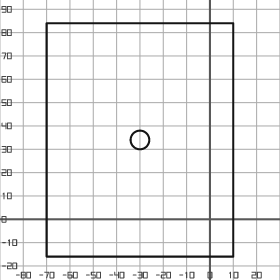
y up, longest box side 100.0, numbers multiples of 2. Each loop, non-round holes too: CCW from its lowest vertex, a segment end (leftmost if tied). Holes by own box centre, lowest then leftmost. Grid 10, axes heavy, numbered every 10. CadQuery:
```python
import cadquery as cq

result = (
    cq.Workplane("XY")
    .moveTo(-70.0, -16.0)
    .lineTo(10.0, -16.0)
    .lineTo(10.0, 84.0)
    .lineTo(-70.0, 84.0)
    .close()
    .moveTo(-30.0, 34.0)
    .circle(4.0)
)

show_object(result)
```